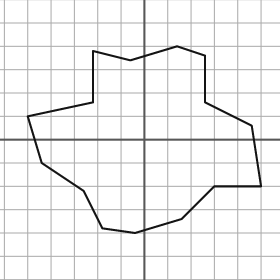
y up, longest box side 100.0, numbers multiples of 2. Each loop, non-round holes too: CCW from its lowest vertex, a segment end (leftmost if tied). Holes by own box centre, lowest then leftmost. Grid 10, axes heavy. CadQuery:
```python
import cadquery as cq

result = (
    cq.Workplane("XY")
    .moveTo(-4.0, -40.0)
    .lineTo(16.0, -34.0)
    .lineTo(30.0, -20.0)
    .lineTo(50.0, -20.0)
    .lineTo(46.0, 6.0)
    .lineTo(26.0, 16.0)
    .lineTo(26.0, 36.0)
    .lineTo(14.0, 40.0)
    .lineTo(-6.0, 34.0)
    .lineTo(-22.0, 38.0)
    .lineTo(-22.0, 16.0)
    .lineTo(-50.0, 10.0)
    .lineTo(-44.0, -10.0)
    .lineTo(-26.0, -22.0)
    .lineTo(-18.0, -38.0)
    .close()
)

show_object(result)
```